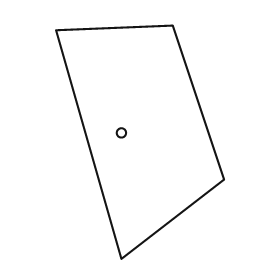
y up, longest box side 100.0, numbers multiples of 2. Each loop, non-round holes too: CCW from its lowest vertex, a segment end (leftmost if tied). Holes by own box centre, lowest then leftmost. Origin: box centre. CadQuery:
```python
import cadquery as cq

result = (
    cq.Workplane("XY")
    .moveTo(-8.0, -50.0)
    .lineTo(36.0, -16.0)
    .lineTo(14.0, 50.0)
    .lineTo(-36.0, 48.0)
    .close()
    .moveTo(-8.0, 4.0)
    .circle(2.0)
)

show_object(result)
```